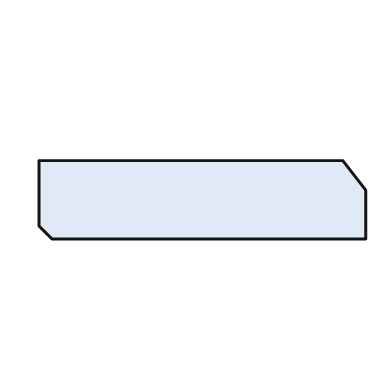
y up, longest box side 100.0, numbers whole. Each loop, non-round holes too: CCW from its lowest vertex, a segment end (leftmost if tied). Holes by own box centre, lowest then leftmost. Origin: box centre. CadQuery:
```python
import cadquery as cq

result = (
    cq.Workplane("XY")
    .moveTo(-46.0, -12.0)
    .lineTo(50.0, -12.0)
    .lineTo(50.0, 3.0)
    .lineTo(43.0, 12.0)
    .lineTo(-50.0, 12.0)
    .lineTo(-50.0, -8.0)
    .close()
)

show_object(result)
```